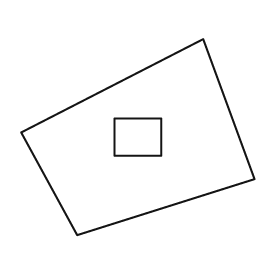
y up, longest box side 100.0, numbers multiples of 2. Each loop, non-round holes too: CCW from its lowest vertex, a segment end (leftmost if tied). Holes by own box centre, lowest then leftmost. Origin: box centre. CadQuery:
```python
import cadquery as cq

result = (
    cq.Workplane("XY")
    .moveTo(-26.0, -42.0)
    .lineTo(50.0, -18.0)
    .lineTo(28.0, 42.0)
    .lineTo(-50.0, 2.0)
    .close()
    .moveTo(-10.0, -8.0)
    .lineTo(10.0, -8.0)
    .lineTo(10.0, 8.0)
    .lineTo(-10.0, 8.0)
    .close()
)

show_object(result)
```